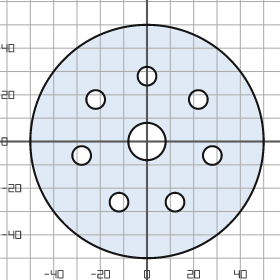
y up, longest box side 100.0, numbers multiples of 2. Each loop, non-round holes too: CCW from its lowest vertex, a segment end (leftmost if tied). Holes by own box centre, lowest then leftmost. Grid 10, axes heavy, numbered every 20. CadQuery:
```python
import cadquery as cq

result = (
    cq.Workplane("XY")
    .moveTo(0.0, 0.0)
    .circle(50.0)
    .moveTo(-12.0, -26.0)
    .circle(4.0)
    .moveTo(12.0, -26.0)
    .circle(4.0)
    .moveTo(-28.0, -6.0)
    .circle(4.0)
    .moveTo(28.0, -6.0)
    .circle(4.0)
    .moveTo(0.0, 0.0)
    .circle(8.0)
    .moveTo(-22.0, 18.0)
    .circle(4.0)
    .moveTo(22.0, 18.0)
    .circle(4.0)
    .moveTo(0.0, 28.0)
    .circle(4.0)
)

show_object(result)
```